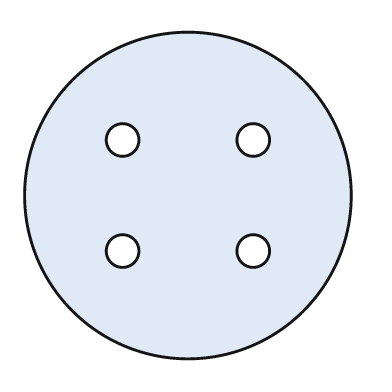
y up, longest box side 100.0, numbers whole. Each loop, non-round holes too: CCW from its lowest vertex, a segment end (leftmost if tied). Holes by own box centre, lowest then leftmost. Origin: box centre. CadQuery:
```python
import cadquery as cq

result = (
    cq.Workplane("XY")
    .moveTo(0.0, 0.0)
    .circle(50.0)
    .moveTo(-20.0, -17.0)
    .circle(5.0)
    .moveTo(20.0, -17.0)
    .circle(5.0)
    .moveTo(-20.0, 17.0)
    .circle(5.0)
    .moveTo(20.0, 17.0)
    .circle(5.0)
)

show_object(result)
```